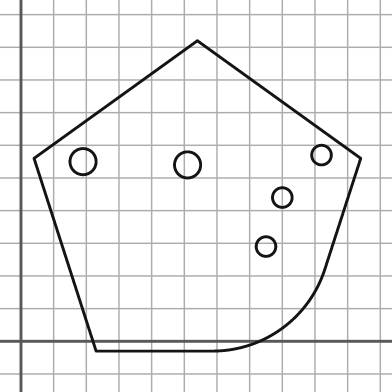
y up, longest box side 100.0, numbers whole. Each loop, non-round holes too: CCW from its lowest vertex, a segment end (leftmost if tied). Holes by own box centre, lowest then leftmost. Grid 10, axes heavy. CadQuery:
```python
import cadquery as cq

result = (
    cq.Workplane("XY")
    .moveTo(23.0, -3.0)
    .lineTo(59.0, -3.0)
    .threePointArc((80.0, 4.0), (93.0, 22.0))
    .lineTo(104.0, 56.0)
    .lineTo(54.0, 92.0)
    .lineTo(4.0, 56.0)
    .close()
    .moveTo(75.0, 29.0)
    .circle(3.0)
    .moveTo(80.0, 44.0)
    .circle(3.0)
    .moveTo(51.0, 54.0)
    .circle(4.0)
    .moveTo(19.0, 55.0)
    .circle(4.0)
    .moveTo(92.0, 57.0)
    .circle(3.0)
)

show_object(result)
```